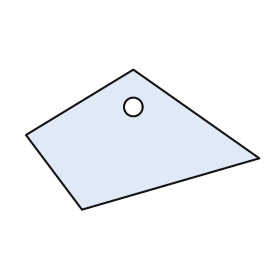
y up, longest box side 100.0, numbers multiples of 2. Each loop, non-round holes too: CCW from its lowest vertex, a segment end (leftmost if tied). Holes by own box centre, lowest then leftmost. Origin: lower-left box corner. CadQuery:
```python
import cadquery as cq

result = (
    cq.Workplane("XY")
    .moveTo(24.0, 0.0)
    .lineTo(100.0, 22.0)
    .lineTo(46.0, 60.0)
    .lineTo(0.0, 32.0)
    .close()
    .moveTo(46.0, 44.0)
    .circle(4.0)
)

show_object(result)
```